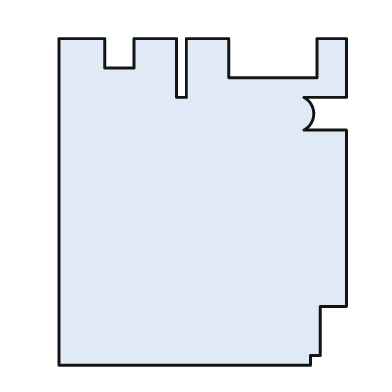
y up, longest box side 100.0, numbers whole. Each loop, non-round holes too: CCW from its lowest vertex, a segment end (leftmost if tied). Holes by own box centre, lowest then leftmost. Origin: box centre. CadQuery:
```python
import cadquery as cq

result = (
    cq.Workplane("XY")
    .moveTo(-44.0, -50.0)
    .lineTo(33.0, -50.0)
    .lineTo(33.0, -47.0)
    .lineTo(36.0, -47.0)
    .lineTo(36.0, -32.0)
    .lineTo(44.0, -32.0)
    .lineTo(44.0, 22.0)
    .lineTo(31.0, 22.0)
    .threePointArc((34.0, 27.0), (31.0, 32.0))
    .lineTo(44.0, 32.0)
    .lineTo(44.0, 50.0)
    .lineTo(35.0, 50.0)
    .lineTo(35.0, 38.0)
    .lineTo(8.0, 38.0)
    .lineTo(8.0, 50.0)
    .lineTo(-5.0, 50.0)
    .lineTo(-5.0, 32.0)
    .lineTo(-8.0, 32.0)
    .lineTo(-8.0, 50.0)
    .lineTo(-21.0, 50.0)
    .lineTo(-21.0, 41.0)
    .lineTo(-30.0, 41.0)
    .lineTo(-30.0, 50.0)
    .lineTo(-44.0, 50.0)
    .close()
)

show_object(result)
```